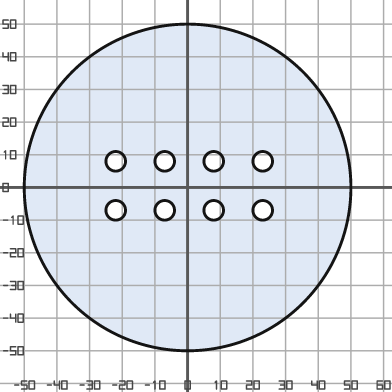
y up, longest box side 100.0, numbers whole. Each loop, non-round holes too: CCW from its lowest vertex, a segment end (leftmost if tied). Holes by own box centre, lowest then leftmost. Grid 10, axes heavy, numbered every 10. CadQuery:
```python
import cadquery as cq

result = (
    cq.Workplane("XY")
    .moveTo(0.0, 0.0)
    .circle(50.0)
    .moveTo(-22.0, -7.0)
    .circle(3.0)
    .moveTo(-7.0, -7.0)
    .circle(3.0)
    .moveTo(8.0, -7.0)
    .circle(3.0)
    .moveTo(23.0, -7.0)
    .circle(3.0)
    .moveTo(-22.0, 8.0)
    .circle(3.0)
    .moveTo(-7.0, 8.0)
    .circle(3.0)
    .moveTo(8.0, 8.0)
    .circle(3.0)
    .moveTo(23.0, 8.0)
    .circle(3.0)
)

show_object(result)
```